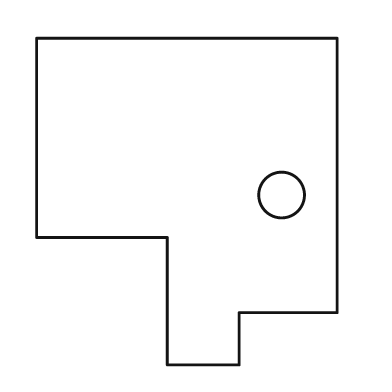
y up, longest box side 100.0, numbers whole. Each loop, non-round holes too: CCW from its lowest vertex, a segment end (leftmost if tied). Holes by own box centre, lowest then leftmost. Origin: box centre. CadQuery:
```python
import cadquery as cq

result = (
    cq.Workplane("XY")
    .moveTo(-6.0, -50.0)
    .lineTo(16.0, -50.0)
    .lineTo(16.0, -34.0)
    .lineTo(46.0, -34.0)
    .lineTo(46.0, 50.0)
    .lineTo(-46.0, 50.0)
    .lineTo(-46.0, -11.0)
    .lineTo(-6.0, -11.0)
    .close()
    .moveTo(29.0, 2.0)
    .circle(7.0)
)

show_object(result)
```